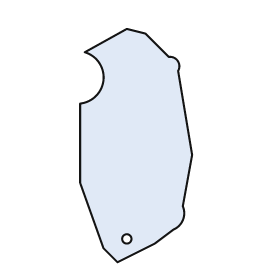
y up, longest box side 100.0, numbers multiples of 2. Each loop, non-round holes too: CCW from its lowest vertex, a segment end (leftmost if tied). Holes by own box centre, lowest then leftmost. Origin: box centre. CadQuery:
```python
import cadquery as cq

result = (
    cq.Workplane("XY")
    .moveTo(-8.0, -50.0)
    .lineTo(8.0, -42.0)
    .lineTo(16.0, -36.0)
    .threePointArc((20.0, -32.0), (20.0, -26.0))
    .lineTo(24.0, -4.0)
    .lineTo(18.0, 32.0)
    .threePointArc((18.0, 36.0), (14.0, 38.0))
    .lineTo(4.0, 48.0)
    .lineTo(-4.0, 50.0)
    .lineTo(-22.0, 40.0)
    .threePointArc((-14.0, 28.0), (-24.0, 18.0))
    .lineTo(-24.0, -16.0)
    .lineTo(-14.0, -44.0)
    .close()
    .moveTo(-4.0, -40.0)
    .circle(2.0)
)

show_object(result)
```